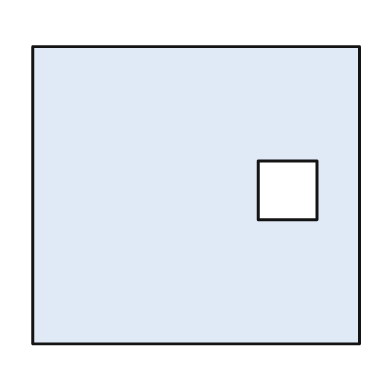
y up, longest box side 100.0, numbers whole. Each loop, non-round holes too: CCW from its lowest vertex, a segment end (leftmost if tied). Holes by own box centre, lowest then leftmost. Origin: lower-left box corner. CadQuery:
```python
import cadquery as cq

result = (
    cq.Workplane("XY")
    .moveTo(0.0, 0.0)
    .lineTo(100.0, 0.0)
    .lineTo(100.0, 91.0)
    .lineTo(0.0, 91.0)
    .close()
    .moveTo(69.0, 38.0)
    .lineTo(87.0, 38.0)
    .lineTo(87.0, 56.0)
    .lineTo(69.0, 56.0)
    .close()
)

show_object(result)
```